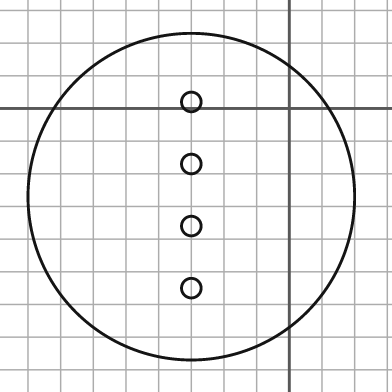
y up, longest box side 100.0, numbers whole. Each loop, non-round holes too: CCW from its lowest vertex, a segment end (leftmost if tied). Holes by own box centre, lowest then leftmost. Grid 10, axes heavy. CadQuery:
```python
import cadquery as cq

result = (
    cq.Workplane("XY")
    .moveTo(-30.0, -27.0)
    .circle(50.0)
    .moveTo(-30.0, -55.0)
    .circle(3.0)
    .moveTo(-30.0, -36.0)
    .circle(3.0)
    .moveTo(-30.0, -17.0)
    .circle(3.0)
    .moveTo(-30.0, 2.0)
    .circle(3.0)
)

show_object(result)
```